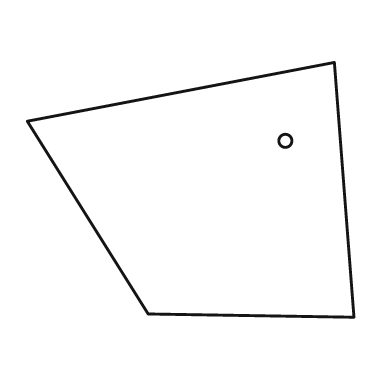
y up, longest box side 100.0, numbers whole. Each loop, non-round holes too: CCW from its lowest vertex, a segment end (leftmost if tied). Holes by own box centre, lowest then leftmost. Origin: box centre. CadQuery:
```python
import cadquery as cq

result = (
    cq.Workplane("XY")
    .moveTo(50.0, -39.0)
    .lineTo(44.0, 39.0)
    .lineTo(-50.0, 21.0)
    .lineTo(-13.0, -38.0)
    .close()
    .moveTo(29.0, 15.0)
    .circle(2.0)
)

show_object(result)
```